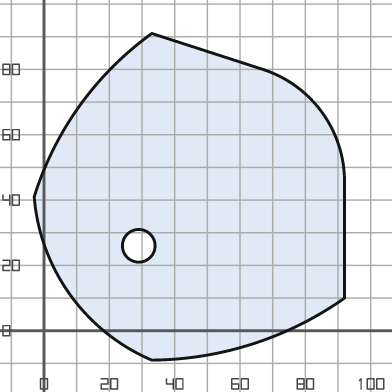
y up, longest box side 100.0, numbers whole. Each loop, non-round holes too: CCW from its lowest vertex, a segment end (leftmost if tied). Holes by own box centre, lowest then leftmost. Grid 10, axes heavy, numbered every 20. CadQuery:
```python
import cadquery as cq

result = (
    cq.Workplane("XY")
    .moveTo(33.0, -9.0)
    .threePointArc((64.0, -4.0), (92.0, 10.0))
    .lineTo(92.0, 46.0)
    .threePointArc((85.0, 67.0), (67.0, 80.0))
    .lineTo(33.0, 91.0)
    .threePointArc((11.0, 69.0), (-3.0, 41.0))
    .threePointArc((8.0, 11.0), (33.0, -9.0))
    .close()
    .moveTo(29.0, 26.0)
    .circle(5.0)
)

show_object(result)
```